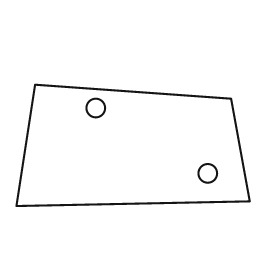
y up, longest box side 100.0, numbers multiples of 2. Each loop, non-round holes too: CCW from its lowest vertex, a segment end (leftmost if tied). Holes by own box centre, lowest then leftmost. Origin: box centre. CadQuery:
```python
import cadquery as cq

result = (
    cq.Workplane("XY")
    .moveTo(-50.0, -26.0)
    .lineTo(50.0, -24.0)
    .lineTo(42.0, 20.0)
    .lineTo(-42.0, 26.0)
    .close()
    .moveTo(32.0, -12.0)
    .circle(4.0)
    .moveTo(-16.0, 16.0)
    .circle(4.0)
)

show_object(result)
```